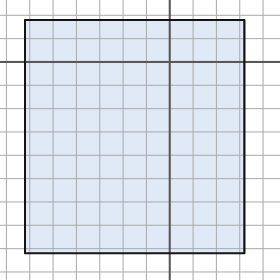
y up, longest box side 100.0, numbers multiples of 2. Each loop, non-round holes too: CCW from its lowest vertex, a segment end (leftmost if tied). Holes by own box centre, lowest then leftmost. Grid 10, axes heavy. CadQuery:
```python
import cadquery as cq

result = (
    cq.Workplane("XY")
    .moveTo(-62.0, -82.0)
    .lineTo(32.0, -82.0)
    .lineTo(32.0, 18.0)
    .lineTo(-62.0, 18.0)
    .close()
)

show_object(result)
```